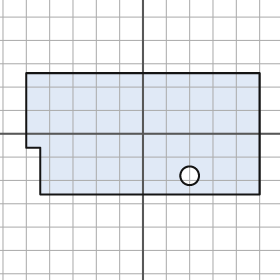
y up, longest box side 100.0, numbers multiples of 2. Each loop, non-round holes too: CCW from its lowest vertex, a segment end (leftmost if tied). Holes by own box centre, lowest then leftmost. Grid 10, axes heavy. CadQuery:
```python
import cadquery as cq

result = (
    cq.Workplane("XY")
    .moveTo(-44.0, -26.0)
    .lineTo(50.0, -26.0)
    .lineTo(50.0, 26.0)
    .lineTo(-50.0, 26.0)
    .lineTo(-50.0, -6.0)
    .lineTo(-44.0, -6.0)
    .close()
    .moveTo(20.0, -18.0)
    .circle(4.0)
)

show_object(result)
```